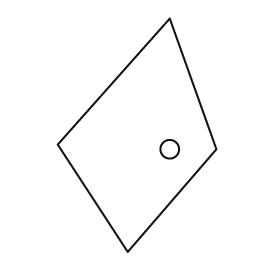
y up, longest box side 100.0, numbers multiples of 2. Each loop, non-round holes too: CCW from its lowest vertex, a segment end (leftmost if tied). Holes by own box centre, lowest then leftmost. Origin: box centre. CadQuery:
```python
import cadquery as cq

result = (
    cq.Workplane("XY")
    .moveTo(-4.0, -50.0)
    .lineTo(34.0, -6.0)
    .lineTo(14.0, 50.0)
    .lineTo(-34.0, -4.0)
    .close()
    .moveTo(14.0, -6.0)
    .circle(4.0)
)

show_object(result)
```